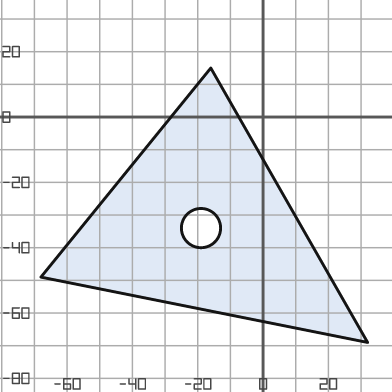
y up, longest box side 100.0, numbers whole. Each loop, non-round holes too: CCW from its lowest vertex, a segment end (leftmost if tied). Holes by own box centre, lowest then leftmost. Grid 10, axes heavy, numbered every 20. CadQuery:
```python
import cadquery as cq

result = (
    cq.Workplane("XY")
    .moveTo(32.0, -69.0)
    .lineTo(-16.0, 15.0)
    .lineTo(-68.0, -49.0)
    .close()
    .moveTo(-19.0, -34.0)
    .circle(6.0)
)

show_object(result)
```